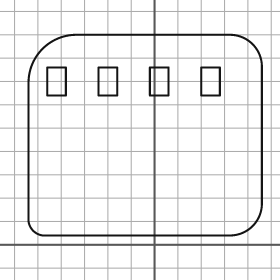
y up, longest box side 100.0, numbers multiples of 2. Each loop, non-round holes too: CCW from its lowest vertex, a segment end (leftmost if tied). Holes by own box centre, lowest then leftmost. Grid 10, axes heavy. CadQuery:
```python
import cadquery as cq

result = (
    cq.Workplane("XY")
    .moveTo(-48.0, 4.0)
    .lineTo(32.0, 4.0)
    .threePointArc((42.0, 8.0), (46.0, 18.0))
    .lineTo(46.0, 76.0)
    .threePointArc((42.0, 86.0), (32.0, 90.0))
    .lineTo(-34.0, 90.0)
    .threePointArc((-48.0, 84.0), (-54.0, 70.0))
    .lineTo(-54.0, 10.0)
    .threePointArc((-52.0, 6.0), (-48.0, 4.0))
    .close()
    .moveTo(-46.0, 64.0)
    .lineTo(-38.0, 64.0)
    .lineTo(-38.0, 76.0)
    .lineTo(-46.0, 76.0)
    .close()
    .moveTo(-24.0, 64.0)
    .lineTo(-16.0, 64.0)
    .lineTo(-16.0, 76.0)
    .lineTo(-24.0, 76.0)
    .close()
    .moveTo(-2.0, 64.0)
    .lineTo(6.0, 64.0)
    .lineTo(6.0, 76.0)
    .lineTo(-2.0, 76.0)
    .close()
    .moveTo(20.0, 64.0)
    .lineTo(28.0, 64.0)
    .lineTo(28.0, 76.0)
    .lineTo(20.0, 76.0)
    .close()
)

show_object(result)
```